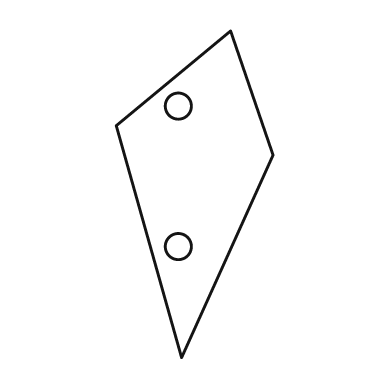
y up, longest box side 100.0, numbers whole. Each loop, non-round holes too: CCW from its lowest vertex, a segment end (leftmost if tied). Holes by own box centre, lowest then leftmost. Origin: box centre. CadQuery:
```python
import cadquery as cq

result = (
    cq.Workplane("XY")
    .moveTo(-4.0, -50.0)
    .lineTo(24.0, 12.0)
    .lineTo(11.0, 50.0)
    .lineTo(-24.0, 21.0)
    .close()
    .moveTo(-5.0, -16.0)
    .circle(4.0)
    .moveTo(-5.0, 27.0)
    .circle(4.0)
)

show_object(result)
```